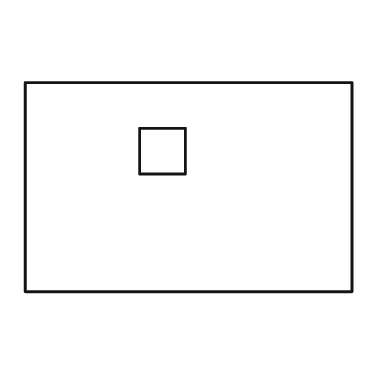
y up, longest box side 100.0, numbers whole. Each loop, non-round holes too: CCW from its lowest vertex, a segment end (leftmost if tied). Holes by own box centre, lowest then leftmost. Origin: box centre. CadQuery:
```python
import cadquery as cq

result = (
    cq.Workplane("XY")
    .moveTo(-50.0, -32.0)
    .lineTo(50.0, -32.0)
    .lineTo(50.0, 32.0)
    .lineTo(-50.0, 32.0)
    .close()
    .moveTo(-15.0, 4.0)
    .lineTo(-1.0, 4.0)
    .lineTo(-1.0, 18.0)
    .lineTo(-15.0, 18.0)
    .close()
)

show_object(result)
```